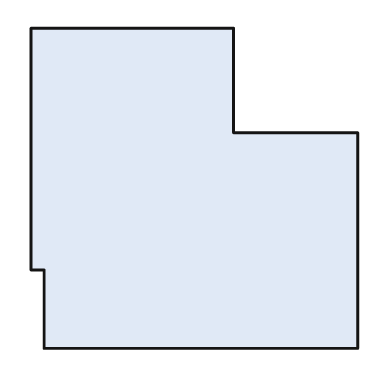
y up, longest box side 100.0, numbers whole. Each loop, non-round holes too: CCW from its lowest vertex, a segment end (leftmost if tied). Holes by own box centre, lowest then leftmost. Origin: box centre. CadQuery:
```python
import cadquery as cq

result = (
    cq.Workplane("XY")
    .moveTo(-46.0, -49.0)
    .lineTo(50.0, -49.0)
    .lineTo(50.0, 17.0)
    .lineTo(12.0, 17.0)
    .lineTo(12.0, 49.0)
    .lineTo(-50.0, 49.0)
    .lineTo(-50.0, -25.0)
    .lineTo(-46.0, -25.0)
    .close()
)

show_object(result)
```